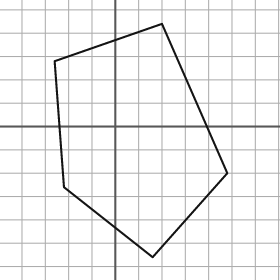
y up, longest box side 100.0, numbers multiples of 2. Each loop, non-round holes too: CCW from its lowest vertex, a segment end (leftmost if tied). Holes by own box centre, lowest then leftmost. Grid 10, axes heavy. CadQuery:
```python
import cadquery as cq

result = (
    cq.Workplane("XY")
    .moveTo(16.0, -56.0)
    .lineTo(48.0, -20.0)
    .lineTo(20.0, 44.0)
    .lineTo(-26.0, 28.0)
    .lineTo(-22.0, -26.0)
    .close()
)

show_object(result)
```